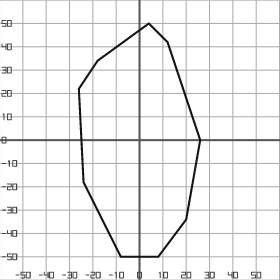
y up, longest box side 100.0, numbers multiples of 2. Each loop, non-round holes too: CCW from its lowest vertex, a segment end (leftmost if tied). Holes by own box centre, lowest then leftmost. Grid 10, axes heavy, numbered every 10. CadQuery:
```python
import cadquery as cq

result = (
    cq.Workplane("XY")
    .moveTo(-8.0, -50.0)
    .lineTo(8.0, -50.0)
    .lineTo(20.0, -34.0)
    .lineTo(26.0, 0.0)
    .lineTo(12.0, 42.0)
    .lineTo(4.0, 50.0)
    .lineTo(-18.0, 34.0)
    .lineTo(-26.0, 22.0)
    .lineTo(-24.0, -18.0)
    .close()
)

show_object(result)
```